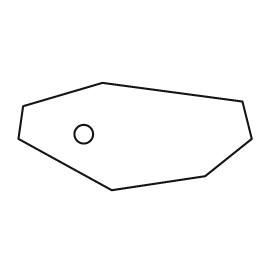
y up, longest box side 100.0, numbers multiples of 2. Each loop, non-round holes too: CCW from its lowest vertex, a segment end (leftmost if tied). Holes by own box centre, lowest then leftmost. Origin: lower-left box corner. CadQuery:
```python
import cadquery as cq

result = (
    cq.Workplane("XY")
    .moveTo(40.0, 0.0)
    .lineTo(80.0, 6.0)
    .lineTo(100.0, 22.0)
    .lineTo(96.0, 38.0)
    .lineTo(36.0, 46.0)
    .lineTo(2.0, 36.0)
    .lineTo(0.0, 22.0)
    .close()
    .moveTo(28.0, 24.0)
    .circle(4.0)
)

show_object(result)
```